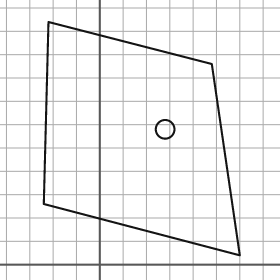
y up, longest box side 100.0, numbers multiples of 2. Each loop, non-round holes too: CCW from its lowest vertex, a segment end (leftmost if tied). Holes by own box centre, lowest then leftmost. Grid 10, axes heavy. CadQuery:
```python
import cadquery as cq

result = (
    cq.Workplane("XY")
    .moveTo(60.0, 4.0)
    .lineTo(48.0, 86.0)
    .lineTo(-22.0, 104.0)
    .lineTo(-24.0, 26.0)
    .close()
    .moveTo(28.0, 58.0)
    .circle(4.0)
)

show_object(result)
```